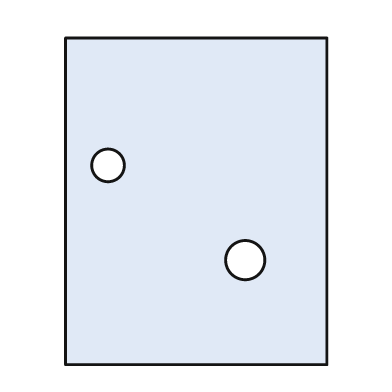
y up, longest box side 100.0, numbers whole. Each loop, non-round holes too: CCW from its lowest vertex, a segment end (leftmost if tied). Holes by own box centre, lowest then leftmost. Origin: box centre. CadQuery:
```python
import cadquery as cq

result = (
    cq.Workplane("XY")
    .moveTo(-40.0, -50.0)
    .lineTo(40.0, -50.0)
    .lineTo(40.0, 50.0)
    .lineTo(-40.0, 50.0)
    .close()
    .moveTo(15.0, -18.0)
    .circle(6.0)
    .moveTo(-27.0, 11.0)
    .circle(5.0)
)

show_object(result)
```